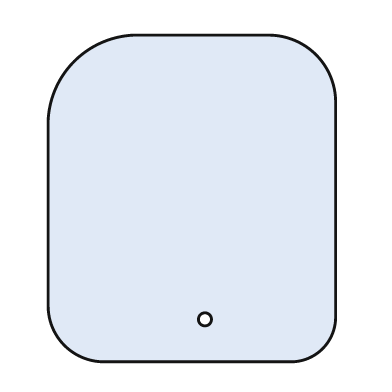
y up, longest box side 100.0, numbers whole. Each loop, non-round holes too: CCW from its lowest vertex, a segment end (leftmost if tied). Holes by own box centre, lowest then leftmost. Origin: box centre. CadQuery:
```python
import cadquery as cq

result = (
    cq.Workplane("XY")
    .moveTo(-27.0, -50.0)
    .lineTo(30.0, -50.0)
    .threePointArc((40.0, -46.0), (44.0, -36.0))
    .lineTo(44.0, 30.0)
    .threePointArc((38.0, 44.0), (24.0, 50.0))
    .lineTo(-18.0, 50.0)
    .threePointArc((-36.0, 42.0), (-44.0, 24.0))
    .lineTo(-44.0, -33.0)
    .threePointArc((-39.0, -45.0), (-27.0, -50.0))
    .close()
    .moveTo(4.0, -37.0)
    .circle(2.0)
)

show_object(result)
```